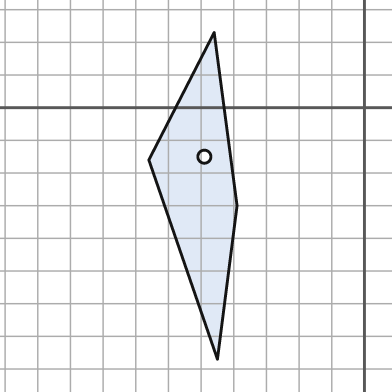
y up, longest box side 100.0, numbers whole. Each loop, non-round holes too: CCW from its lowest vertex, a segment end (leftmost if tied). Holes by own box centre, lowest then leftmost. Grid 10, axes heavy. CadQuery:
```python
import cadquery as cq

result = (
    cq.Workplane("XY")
    .moveTo(-45.0, -77.0)
    .lineTo(-39.0, -30.0)
    .lineTo(-46.0, 23.0)
    .lineTo(-66.0, -16.0)
    .close()
    .moveTo(-49.0, -15.0)
    .circle(2.0)
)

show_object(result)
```